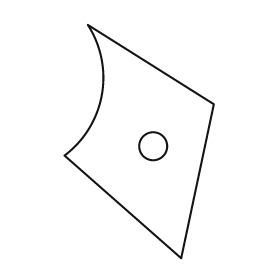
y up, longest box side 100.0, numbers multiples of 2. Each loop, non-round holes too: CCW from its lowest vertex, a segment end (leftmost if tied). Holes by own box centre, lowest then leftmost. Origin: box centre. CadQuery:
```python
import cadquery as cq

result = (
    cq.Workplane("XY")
    .moveTo(18.0, -50.0)
    .lineTo(32.0, 16.0)
    .lineTo(-22.0, 50.0)
    .threePointArc((-16.0, 20.0), (-32.0, -6.0))
    .close()
    .moveTo(6.0, -2.0)
    .circle(6.0)
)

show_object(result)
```